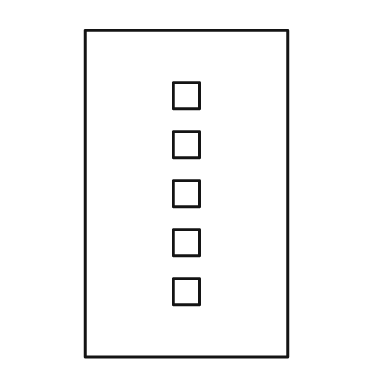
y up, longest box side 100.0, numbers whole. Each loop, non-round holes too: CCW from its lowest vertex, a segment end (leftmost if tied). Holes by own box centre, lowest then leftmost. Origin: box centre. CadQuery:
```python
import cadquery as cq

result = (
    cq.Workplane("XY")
    .moveTo(-31.0, -50.0)
    .lineTo(31.0, -50.0)
    .lineTo(31.0, 50.0)
    .lineTo(-31.0, 50.0)
    .close()
    .moveTo(-4.0, -34.0)
    .lineTo(4.0, -34.0)
    .lineTo(4.0, -26.0)
    .lineTo(-4.0, -26.0)
    .close()
    .moveTo(-4.0, -19.0)
    .lineTo(4.0, -19.0)
    .lineTo(4.0, -11.0)
    .lineTo(-4.0, -11.0)
    .close()
    .moveTo(-4.0, -4.0)
    .lineTo(4.0, -4.0)
    .lineTo(4.0, 4.0)
    .lineTo(-4.0, 4.0)
    .close()
    .moveTo(-4.0, 11.0)
    .lineTo(4.0, 11.0)
    .lineTo(4.0, 19.0)
    .lineTo(-4.0, 19.0)
    .close()
    .moveTo(-4.0, 26.0)
    .lineTo(4.0, 26.0)
    .lineTo(4.0, 34.0)
    .lineTo(-4.0, 34.0)
    .close()
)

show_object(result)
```